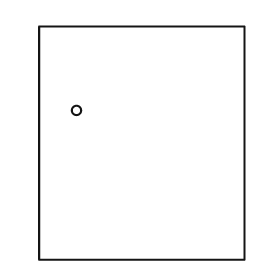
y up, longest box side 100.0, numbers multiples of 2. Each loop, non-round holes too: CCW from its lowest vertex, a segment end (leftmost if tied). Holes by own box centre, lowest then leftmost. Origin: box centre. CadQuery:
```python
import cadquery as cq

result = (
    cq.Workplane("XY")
    .moveTo(-44.0, -50.0)
    .lineTo(44.0, -50.0)
    .lineTo(44.0, 50.0)
    .lineTo(-44.0, 50.0)
    .close()
    .moveTo(-28.0, 14.0)
    .circle(2.0)
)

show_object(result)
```